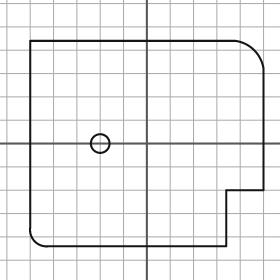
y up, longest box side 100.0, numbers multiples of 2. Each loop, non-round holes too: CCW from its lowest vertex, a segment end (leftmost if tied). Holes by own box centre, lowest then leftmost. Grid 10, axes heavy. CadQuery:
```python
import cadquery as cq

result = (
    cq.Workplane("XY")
    .moveTo(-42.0, -44.0)
    .lineTo(34.0, -44.0)
    .lineTo(34.0, -20.0)
    .lineTo(50.0, -20.0)
    .lineTo(50.0, 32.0)
    .threePointArc((46.0, 40.0), (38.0, 44.0))
    .lineTo(-50.0, 44.0)
    .lineTo(-50.0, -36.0)
    .threePointArc((-48.0, -42.0), (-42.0, -44.0))
    .close()
    .moveTo(-20.0, 0.0)
    .circle(4.0)
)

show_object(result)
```